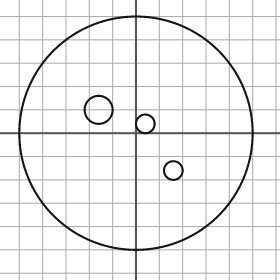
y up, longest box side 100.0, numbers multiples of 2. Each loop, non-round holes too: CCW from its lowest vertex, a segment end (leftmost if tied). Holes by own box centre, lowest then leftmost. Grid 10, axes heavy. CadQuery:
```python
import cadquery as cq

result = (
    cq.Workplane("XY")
    .moveTo(0.0, 0.0)
    .circle(50.0)
    .moveTo(16.0, -16.0)
    .circle(4.0)
    .moveTo(4.0, 4.0)
    .circle(4.0)
    .moveTo(-16.0, 10.0)
    .circle(6.0)
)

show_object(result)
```